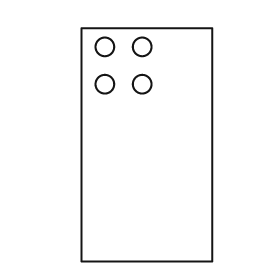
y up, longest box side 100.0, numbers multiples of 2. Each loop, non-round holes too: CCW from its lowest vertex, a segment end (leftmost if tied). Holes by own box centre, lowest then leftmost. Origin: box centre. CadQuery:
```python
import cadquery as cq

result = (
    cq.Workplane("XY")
    .moveTo(-28.0, -50.0)
    .lineTo(28.0, -50.0)
    .lineTo(28.0, 50.0)
    .lineTo(-28.0, 50.0)
    .close()
    .moveTo(-18.0, 26.0)
    .circle(4.0)
    .moveTo(-2.0, 26.0)
    .circle(4.0)
    .moveTo(-18.0, 42.0)
    .circle(4.0)
    .moveTo(-2.0, 42.0)
    .circle(4.0)
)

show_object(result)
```